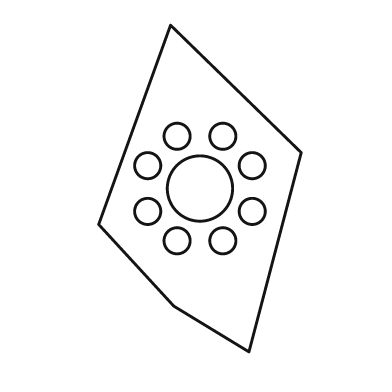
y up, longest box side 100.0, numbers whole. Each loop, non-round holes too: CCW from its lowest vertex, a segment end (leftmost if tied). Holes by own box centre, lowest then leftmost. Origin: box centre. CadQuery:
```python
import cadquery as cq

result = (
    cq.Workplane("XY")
    .moveTo(15.0, -50.0)
    .lineTo(31.0, 11.0)
    .lineTo(-9.0, 50.0)
    .lineTo(-31.0, -11.0)
    .lineTo(-8.0, -36.0)
    .close()
    .moveTo(-7.0, -16.0)
    .circle(4.0)
    .moveTo(7.0, -16.0)
    .circle(4.0)
    .moveTo(-16.0, -7.0)
    .circle(4.0)
    .moveTo(16.0, -7.0)
    .circle(4.0)
    .moveTo(0.0, 0.0)
    .circle(10.0)
    .moveTo(-16.0, 7.0)
    .circle(4.0)
    .moveTo(16.0, 7.0)
    .circle(4.0)
    .moveTo(-7.0, 16.0)
    .circle(4.0)
    .moveTo(7.0, 16.0)
    .circle(4.0)
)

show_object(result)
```